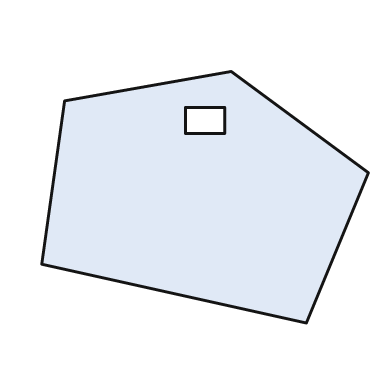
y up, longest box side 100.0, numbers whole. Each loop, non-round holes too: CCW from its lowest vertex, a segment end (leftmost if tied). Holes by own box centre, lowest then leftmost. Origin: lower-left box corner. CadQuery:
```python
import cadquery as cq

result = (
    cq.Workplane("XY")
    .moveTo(81.0, 0.0)
    .lineTo(100.0, 46.0)
    .lineTo(58.0, 77.0)
    .lineTo(7.0, 68.0)
    .lineTo(0.0, 18.0)
    .close()
    .moveTo(44.0, 58.0)
    .lineTo(56.0, 58.0)
    .lineTo(56.0, 66.0)
    .lineTo(44.0, 66.0)
    .close()
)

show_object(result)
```